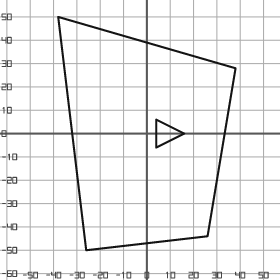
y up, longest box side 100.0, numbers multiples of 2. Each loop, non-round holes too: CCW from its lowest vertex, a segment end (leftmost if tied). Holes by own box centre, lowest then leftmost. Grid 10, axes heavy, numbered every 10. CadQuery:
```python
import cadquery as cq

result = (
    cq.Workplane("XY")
    .moveTo(-26.0, -50.0)
    .lineTo(26.0, -44.0)
    .lineTo(38.0, 28.0)
    .lineTo(-38.0, 50.0)
    .close()
    .moveTo(4.0, -6.0)
    .lineTo(16.0, 0.0)
    .lineTo(4.0, 6.0)
    .close()
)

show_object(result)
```